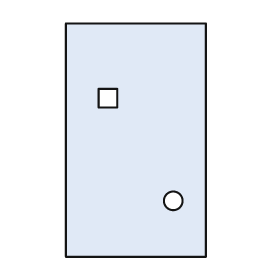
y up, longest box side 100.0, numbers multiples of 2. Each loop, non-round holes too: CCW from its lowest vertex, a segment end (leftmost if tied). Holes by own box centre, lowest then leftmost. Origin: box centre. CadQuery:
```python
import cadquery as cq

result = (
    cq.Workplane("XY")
    .moveTo(-30.0, -50.0)
    .lineTo(30.0, -50.0)
    .lineTo(30.0, 50.0)
    .lineTo(-30.0, 50.0)
    .close()
    .moveTo(16.0, -26.0)
    .circle(4.0)
    .moveTo(-16.0, 14.0)
    .lineTo(-8.0, 14.0)
    .lineTo(-8.0, 22.0)
    .lineTo(-16.0, 22.0)
    .close()
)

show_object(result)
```